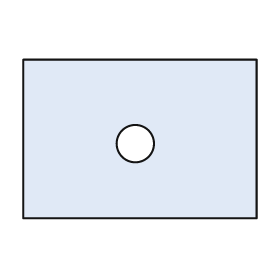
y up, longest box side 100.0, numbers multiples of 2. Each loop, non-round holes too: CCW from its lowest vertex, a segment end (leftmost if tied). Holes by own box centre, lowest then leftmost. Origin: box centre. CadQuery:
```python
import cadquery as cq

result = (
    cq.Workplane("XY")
    .moveTo(-50.0, -34.0)
    .lineTo(50.0, -34.0)
    .lineTo(50.0, 34.0)
    .lineTo(-50.0, 34.0)
    .close()
    .moveTo(-2.0, -2.0)
    .circle(8.0)
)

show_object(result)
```